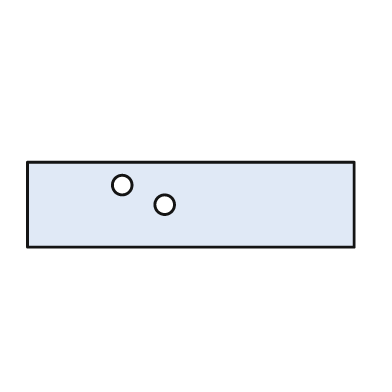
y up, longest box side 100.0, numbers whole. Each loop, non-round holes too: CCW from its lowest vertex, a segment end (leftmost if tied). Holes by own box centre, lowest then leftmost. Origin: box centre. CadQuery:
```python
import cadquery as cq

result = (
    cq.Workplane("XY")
    .moveTo(-50.0, -13.0)
    .lineTo(50.0, -13.0)
    .lineTo(50.0, 13.0)
    .lineTo(-50.0, 13.0)
    .close()
    .moveTo(-8.0, 0.0)
    .circle(3.0)
    .moveTo(-21.0, 6.0)
    .circle(3.0)
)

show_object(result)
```